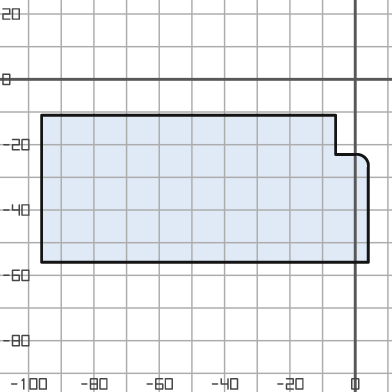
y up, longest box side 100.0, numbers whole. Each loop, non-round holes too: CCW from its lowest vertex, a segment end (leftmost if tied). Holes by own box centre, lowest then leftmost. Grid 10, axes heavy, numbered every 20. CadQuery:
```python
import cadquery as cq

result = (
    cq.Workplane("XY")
    .moveTo(-96.0, -56.0)
    .lineTo(4.0, -56.0)
    .lineTo(4.0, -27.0)
    .threePointArc((3.0, -24.0), (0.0, -23.0))
    .lineTo(-6.0, -23.0)
    .lineTo(-6.0, -11.0)
    .lineTo(-96.0, -11.0)
    .close()
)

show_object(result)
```